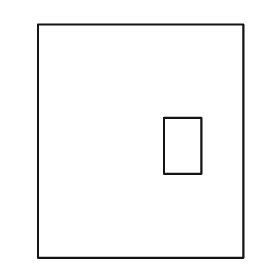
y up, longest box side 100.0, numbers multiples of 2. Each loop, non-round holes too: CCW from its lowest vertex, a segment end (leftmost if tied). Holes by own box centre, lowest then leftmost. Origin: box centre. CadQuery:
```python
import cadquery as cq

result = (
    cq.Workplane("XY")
    .moveTo(-44.0, -50.0)
    .lineTo(44.0, -50.0)
    .lineTo(44.0, 50.0)
    .lineTo(-44.0, 50.0)
    .close()
    .moveTo(10.0, -14.0)
    .lineTo(26.0, -14.0)
    .lineTo(26.0, 10.0)
    .lineTo(10.0, 10.0)
    .close()
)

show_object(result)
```